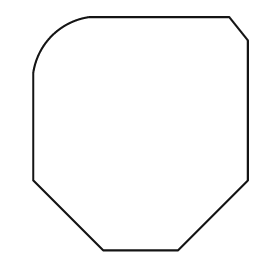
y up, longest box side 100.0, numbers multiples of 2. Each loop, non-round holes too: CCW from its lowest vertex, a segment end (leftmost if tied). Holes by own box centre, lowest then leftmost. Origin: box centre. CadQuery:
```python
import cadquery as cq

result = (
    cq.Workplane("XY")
    .moveTo(-16.0, -50.0)
    .lineTo(16.0, -50.0)
    .lineTo(46.0, -20.0)
    .lineTo(46.0, 40.0)
    .lineTo(38.0, 50.0)
    .lineTo(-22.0, 50.0)
    .threePointArc((-38.0, 42.0), (-46.0, 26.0))
    .lineTo(-46.0, -20.0)
    .close()
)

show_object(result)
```